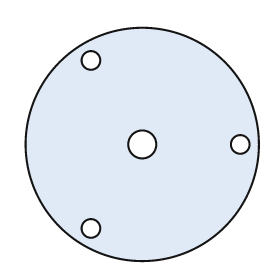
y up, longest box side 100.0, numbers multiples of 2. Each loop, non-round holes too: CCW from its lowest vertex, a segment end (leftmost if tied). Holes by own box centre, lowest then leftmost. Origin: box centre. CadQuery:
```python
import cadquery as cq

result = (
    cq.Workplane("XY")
    .moveTo(0.0, 0.0)
    .circle(50.0)
    .moveTo(-22.0, -36.0)
    .circle(4.0)
    .moveTo(0.0, 0.0)
    .circle(6.0)
    .moveTo(42.0, 0.0)
    .circle(4.0)
    .moveTo(-22.0, 36.0)
    .circle(4.0)
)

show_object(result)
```